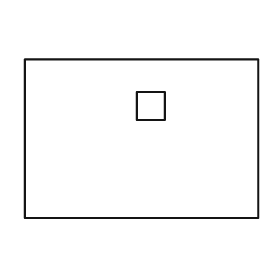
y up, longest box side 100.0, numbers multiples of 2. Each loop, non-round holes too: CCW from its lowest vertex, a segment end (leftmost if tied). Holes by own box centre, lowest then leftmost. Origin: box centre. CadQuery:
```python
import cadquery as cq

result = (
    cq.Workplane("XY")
    .moveTo(-50.0, -34.0)
    .lineTo(50.0, -34.0)
    .lineTo(50.0, 34.0)
    .lineTo(-50.0, 34.0)
    .close()
    .moveTo(-2.0, 8.0)
    .lineTo(10.0, 8.0)
    .lineTo(10.0, 20.0)
    .lineTo(-2.0, 20.0)
    .close()
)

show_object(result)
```